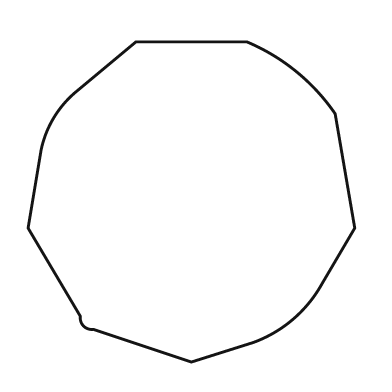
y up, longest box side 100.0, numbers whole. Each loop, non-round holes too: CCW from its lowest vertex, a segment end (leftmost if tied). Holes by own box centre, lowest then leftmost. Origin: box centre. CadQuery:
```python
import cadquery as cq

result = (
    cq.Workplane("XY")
    .moveTo(0.0, -49.0)
    .lineTo(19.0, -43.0)
    .threePointArc((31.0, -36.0), (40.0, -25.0))
    .lineTo(50.0, -8.0)
    .lineTo(44.0, 27.0)
    .threePointArc((32.0, 40.0), (17.0, 49.0))
    .lineTo(-17.0, 49.0)
    .lineTo(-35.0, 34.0)
    .threePointArc((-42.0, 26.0), (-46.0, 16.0))
    .lineTo(-50.0, -8.0)
    .lineTo(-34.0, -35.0)
    .threePointArc((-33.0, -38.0), (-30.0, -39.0))
    .close()
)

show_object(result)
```